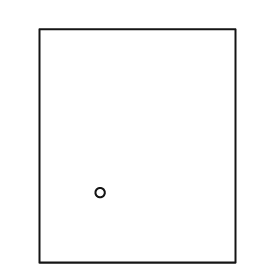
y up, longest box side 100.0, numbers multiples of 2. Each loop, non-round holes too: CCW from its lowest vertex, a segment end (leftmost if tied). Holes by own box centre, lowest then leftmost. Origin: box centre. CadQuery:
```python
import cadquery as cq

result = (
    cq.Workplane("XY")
    .moveTo(-42.0, -50.0)
    .lineTo(42.0, -50.0)
    .lineTo(42.0, 50.0)
    .lineTo(-42.0, 50.0)
    .close()
    .moveTo(-16.0, -20.0)
    .circle(2.0)
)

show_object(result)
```